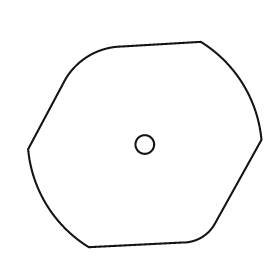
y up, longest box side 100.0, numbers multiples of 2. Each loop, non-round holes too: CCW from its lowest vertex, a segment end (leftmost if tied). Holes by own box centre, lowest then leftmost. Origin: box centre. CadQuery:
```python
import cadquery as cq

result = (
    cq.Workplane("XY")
    .moveTo(-24.0, -44.0)
    .lineTo(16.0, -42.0)
    .threePointArc((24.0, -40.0), (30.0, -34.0))
    .lineTo(50.0, 2.0)
    .threePointArc((42.0, 26.0), (24.0, 44.0))
    .lineTo(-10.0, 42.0)
    .threePointArc((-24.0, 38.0), (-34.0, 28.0))
    .lineTo(-50.0, -2.0)
    .threePointArc((-42.0, -26.0), (-24.0, -44.0))
    .close()
    .moveTo(0.0, 0.0)
    .circle(4.0)
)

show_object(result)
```